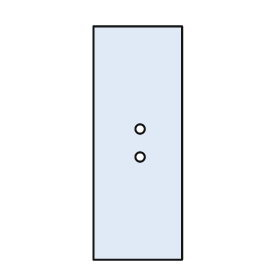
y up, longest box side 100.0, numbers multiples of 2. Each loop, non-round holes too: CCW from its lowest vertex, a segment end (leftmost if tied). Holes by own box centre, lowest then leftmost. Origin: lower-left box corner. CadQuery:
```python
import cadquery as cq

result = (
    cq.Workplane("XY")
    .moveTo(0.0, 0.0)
    .lineTo(38.0, 0.0)
    .lineTo(38.0, 100.0)
    .lineTo(0.0, 100.0)
    .close()
    .moveTo(20.0, 44.0)
    .circle(2.0)
    .moveTo(20.0, 56.0)
    .circle(2.0)
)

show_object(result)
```